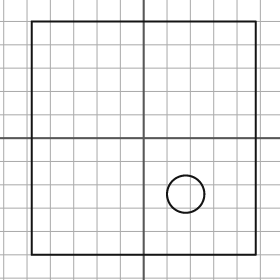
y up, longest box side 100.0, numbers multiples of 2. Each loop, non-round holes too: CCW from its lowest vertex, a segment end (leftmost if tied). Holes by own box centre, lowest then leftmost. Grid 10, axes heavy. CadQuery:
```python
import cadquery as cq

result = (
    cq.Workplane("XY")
    .moveTo(-48.0, -50.0)
    .lineTo(48.0, -50.0)
    .lineTo(48.0, 50.0)
    .lineTo(-48.0, 50.0)
    .close()
    .moveTo(18.0, -24.0)
    .circle(8.0)
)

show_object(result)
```